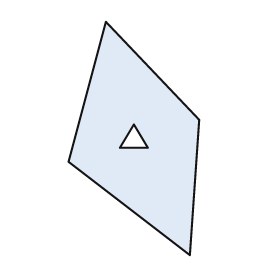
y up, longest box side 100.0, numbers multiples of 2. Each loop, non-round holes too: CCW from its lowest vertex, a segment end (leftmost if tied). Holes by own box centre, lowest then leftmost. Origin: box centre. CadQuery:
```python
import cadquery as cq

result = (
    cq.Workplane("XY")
    .moveTo(24.0, -50.0)
    .lineTo(28.0, 8.0)
    .lineTo(-12.0, 50.0)
    .lineTo(-28.0, -10.0)
    .close()
    .moveTo(-6.0, -4.0)
    .lineTo(6.0, -4.0)
    .lineTo(0.0, 6.0)
    .close()
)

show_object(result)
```